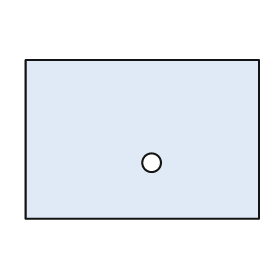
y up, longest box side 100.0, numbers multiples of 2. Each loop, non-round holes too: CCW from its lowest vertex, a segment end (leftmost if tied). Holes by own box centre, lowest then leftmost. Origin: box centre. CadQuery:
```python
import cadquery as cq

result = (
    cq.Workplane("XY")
    .moveTo(-50.0, -34.0)
    .lineTo(50.0, -34.0)
    .lineTo(50.0, 34.0)
    .lineTo(-50.0, 34.0)
    .close()
    .moveTo(4.0, -10.0)
    .circle(4.0)
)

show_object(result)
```